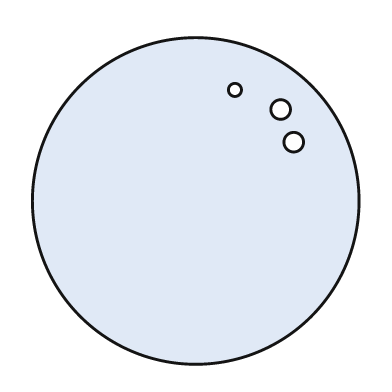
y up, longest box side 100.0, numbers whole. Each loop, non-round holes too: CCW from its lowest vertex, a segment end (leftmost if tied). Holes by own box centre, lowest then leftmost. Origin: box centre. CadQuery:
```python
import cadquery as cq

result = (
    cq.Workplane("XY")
    .moveTo(0.0, 0.0)
    .circle(50.0)
    .moveTo(30.0, 18.0)
    .circle(3.0)
    .moveTo(26.0, 28.0)
    .circle(3.0)
    .moveTo(12.0, 34.0)
    .circle(2.0)
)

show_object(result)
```